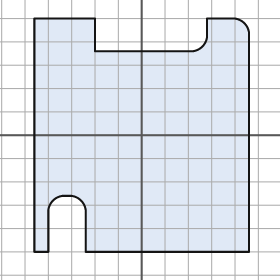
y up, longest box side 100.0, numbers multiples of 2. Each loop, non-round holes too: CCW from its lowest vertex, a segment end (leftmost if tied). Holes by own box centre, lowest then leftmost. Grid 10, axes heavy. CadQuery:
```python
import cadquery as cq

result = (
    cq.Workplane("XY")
    .moveTo(-46.0, -50.0)
    .lineTo(-40.0, -50.0)
    .lineTo(-40.0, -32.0)
    .threePointArc((-38.0, -28.0), (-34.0, -26.0))
    .lineTo(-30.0, -26.0)
    .threePointArc((-26.0, -28.0), (-24.0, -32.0))
    .lineTo(-24.0, -50.0)
    .lineTo(46.0, -50.0)
    .lineTo(46.0, 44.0)
    .threePointArc((44.0, 48.0), (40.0, 50.0))
    .lineTo(28.0, 50.0)
    .lineTo(28.0, 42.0)
    .threePointArc((26.0, 38.0), (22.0, 36.0))
    .lineTo(-20.0, 36.0)
    .lineTo(-20.0, 50.0)
    .lineTo(-46.0, 50.0)
    .close()
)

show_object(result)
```